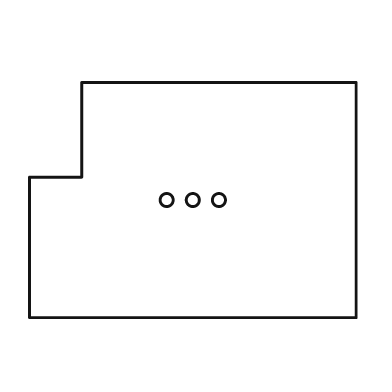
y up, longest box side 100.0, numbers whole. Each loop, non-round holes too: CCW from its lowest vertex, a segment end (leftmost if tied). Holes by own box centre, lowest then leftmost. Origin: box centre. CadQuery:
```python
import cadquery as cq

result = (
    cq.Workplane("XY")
    .moveTo(-50.0, -36.0)
    .lineTo(50.0, -36.0)
    .lineTo(50.0, 36.0)
    .lineTo(-34.0, 36.0)
    .lineTo(-34.0, 7.0)
    .lineTo(-50.0, 7.0)
    .close()
    .moveTo(-8.0, 0.0)
    .circle(2.0)
    .moveTo(0.0, 0.0)
    .circle(2.0)
    .moveTo(8.0, 0.0)
    .circle(2.0)
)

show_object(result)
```